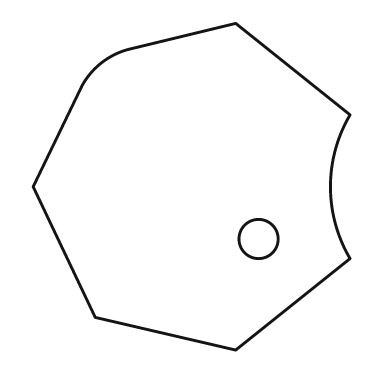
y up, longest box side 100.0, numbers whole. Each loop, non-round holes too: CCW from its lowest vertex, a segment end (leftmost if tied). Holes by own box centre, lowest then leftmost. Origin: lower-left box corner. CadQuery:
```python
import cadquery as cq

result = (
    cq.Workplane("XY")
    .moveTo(62.0, 0.0)
    .lineTo(97.0, 28.0)
    .threePointArc((91.0, 50.0), (97.0, 72.0))
    .lineTo(62.0, 100.0)
    .lineTo(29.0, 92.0)
    .threePointArc((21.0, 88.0), (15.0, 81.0))
    .lineTo(0.0, 50.0)
    .lineTo(19.0, 10.0)
    .close()
    .moveTo(69.0, 34.0)
    .circle(6.0)
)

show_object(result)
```